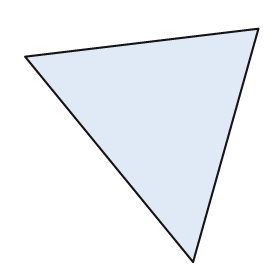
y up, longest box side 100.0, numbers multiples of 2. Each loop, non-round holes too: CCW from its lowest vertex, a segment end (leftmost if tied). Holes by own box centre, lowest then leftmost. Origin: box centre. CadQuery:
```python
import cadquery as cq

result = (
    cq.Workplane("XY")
    .moveTo(22.0, -50.0)
    .lineTo(50.0, 50.0)
    .lineTo(-50.0, 38.0)
    .close()
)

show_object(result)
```